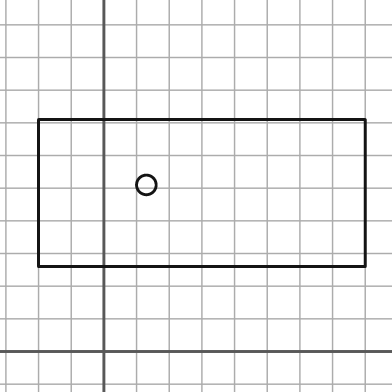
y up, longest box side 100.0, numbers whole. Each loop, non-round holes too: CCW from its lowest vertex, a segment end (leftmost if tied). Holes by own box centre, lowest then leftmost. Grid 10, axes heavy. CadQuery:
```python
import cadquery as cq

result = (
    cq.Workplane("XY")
    .moveTo(-20.0, 26.0)
    .lineTo(80.0, 26.0)
    .lineTo(80.0, 71.0)
    .lineTo(-20.0, 71.0)
    .close()
    .moveTo(13.0, 51.0)
    .circle(3.0)
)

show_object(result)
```